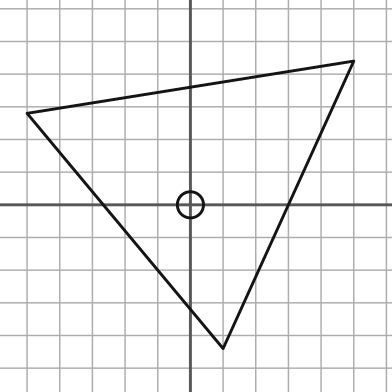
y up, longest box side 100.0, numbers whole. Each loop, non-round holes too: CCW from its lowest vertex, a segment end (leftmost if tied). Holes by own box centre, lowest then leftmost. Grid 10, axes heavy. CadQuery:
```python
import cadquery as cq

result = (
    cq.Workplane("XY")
    .moveTo(10.0, -44.0)
    .lineTo(50.0, 44.0)
    .lineTo(-50.0, 28.0)
    .close()
    .moveTo(0.0, 0.0)
    .circle(4.0)
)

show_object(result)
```